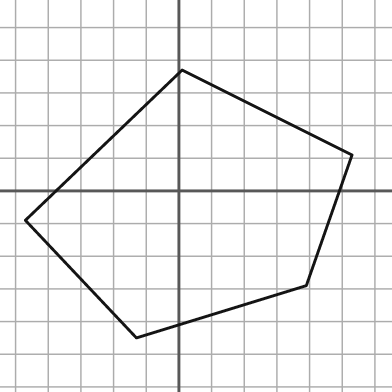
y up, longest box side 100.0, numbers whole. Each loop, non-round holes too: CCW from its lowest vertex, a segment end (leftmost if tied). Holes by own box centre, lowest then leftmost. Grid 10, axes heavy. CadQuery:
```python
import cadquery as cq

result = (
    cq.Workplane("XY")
    .moveTo(-13.0, -45.0)
    .lineTo(39.0, -29.0)
    .lineTo(53.0, 11.0)
    .lineTo(1.0, 37.0)
    .lineTo(-47.0, -9.0)
    .close()
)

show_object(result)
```